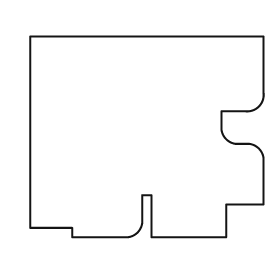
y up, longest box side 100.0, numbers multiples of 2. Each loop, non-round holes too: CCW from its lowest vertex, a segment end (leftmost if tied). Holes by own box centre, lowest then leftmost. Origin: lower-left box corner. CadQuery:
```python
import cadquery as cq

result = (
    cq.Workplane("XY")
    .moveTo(18.0, 0.0)
    .lineTo(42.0, 0.0)
    .threePointArc((46.0, 2.0), (48.0, 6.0))
    .lineTo(48.0, 18.0)
    .lineTo(52.0, 18.0)
    .lineTo(52.0, 0.0)
    .lineTo(84.0, 0.0)
    .lineTo(84.0, 14.0)
    .lineTo(100.0, 14.0)
    .lineTo(100.0, 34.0)
    .threePointArc((98.0, 38.0), (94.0, 40.0))
    .lineTo(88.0, 40.0)
    .threePointArc((84.0, 42.0), (82.0, 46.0))
    .lineTo(82.0, 54.0)
    .lineTo(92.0, 54.0)
    .threePointArc((98.0, 56.0), (100.0, 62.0))
    .lineTo(100.0, 86.0)
    .lineTo(0.0, 86.0)
    .lineTo(0.0, 4.0)
    .lineTo(18.0, 4.0)
    .close()
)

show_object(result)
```